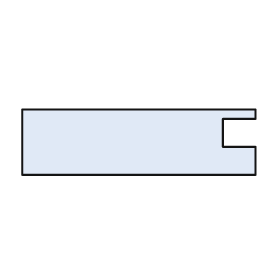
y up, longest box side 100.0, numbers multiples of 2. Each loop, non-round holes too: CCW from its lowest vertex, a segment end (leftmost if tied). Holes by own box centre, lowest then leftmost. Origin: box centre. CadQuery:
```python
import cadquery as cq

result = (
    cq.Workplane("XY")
    .moveTo(-50.0, -14.0)
    .lineTo(50.0, -14.0)
    .lineTo(50.0, -2.0)
    .lineTo(36.0, -2.0)
    .lineTo(36.0, 10.0)
    .lineTo(50.0, 10.0)
    .lineTo(50.0, 14.0)
    .lineTo(-50.0, 14.0)
    .close()
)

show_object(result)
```